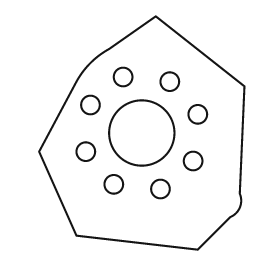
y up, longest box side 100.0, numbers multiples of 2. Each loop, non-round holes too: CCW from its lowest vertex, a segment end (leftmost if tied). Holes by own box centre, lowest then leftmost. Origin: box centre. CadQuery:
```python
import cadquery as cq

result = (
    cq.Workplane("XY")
    .moveTo(24.0, -50.0)
    .lineTo(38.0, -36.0)
    .threePointArc((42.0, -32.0), (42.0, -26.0))
    .lineTo(44.0, 20.0)
    .lineTo(6.0, 50.0)
    .lineTo(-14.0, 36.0)
    .threePointArc((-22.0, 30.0), (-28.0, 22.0))
    .lineTo(-44.0, -8.0)
    .lineTo(-28.0, -44.0)
    .close()
    .moveTo(8.0, -24.0)
    .circle(4.0)
    .moveTo(-12.0, -22.0)
    .circle(4.0)
    .moveTo(22.0, -12.0)
    .circle(4.0)
    .moveTo(-24.0, -8.0)
    .circle(4.0)
    .moveTo(0.0, 0.0)
    .circle(14.0)
    .moveTo(24.0, 8.0)
    .circle(4.0)
    .moveTo(-22.0, 12.0)
    .circle(4.0)
    .moveTo(12.0, 22.0)
    .circle(4.0)
    .moveTo(-8.0, 24.0)
    .circle(4.0)
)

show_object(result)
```